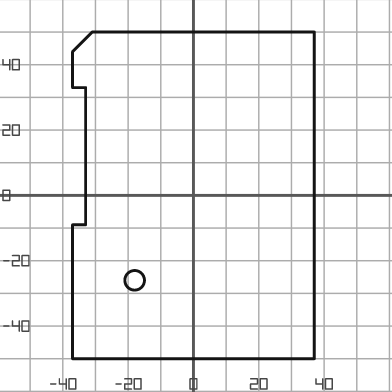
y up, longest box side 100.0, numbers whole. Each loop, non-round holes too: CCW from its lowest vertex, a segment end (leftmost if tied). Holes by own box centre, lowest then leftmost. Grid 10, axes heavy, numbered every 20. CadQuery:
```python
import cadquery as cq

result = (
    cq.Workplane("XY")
    .moveTo(-37.0, -50.0)
    .lineTo(37.0, -50.0)
    .lineTo(37.0, 50.0)
    .lineTo(-31.0, 50.0)
    .lineTo(-37.0, 44.0)
    .lineTo(-37.0, 33.0)
    .lineTo(-33.0, 33.0)
    .lineTo(-33.0, -9.0)
    .lineTo(-37.0, -9.0)
    .close()
    .moveTo(-18.0, -26.0)
    .circle(3.0)
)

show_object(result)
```